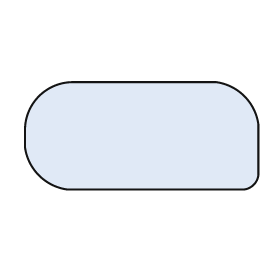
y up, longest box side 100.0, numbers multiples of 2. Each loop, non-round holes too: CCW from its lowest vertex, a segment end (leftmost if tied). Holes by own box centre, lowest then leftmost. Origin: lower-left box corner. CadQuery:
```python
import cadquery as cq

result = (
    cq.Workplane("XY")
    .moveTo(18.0, 0.0)
    .lineTo(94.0, 0.0)
    .threePointArc((98.0, 2.0), (100.0, 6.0))
    .lineTo(100.0, 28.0)
    .threePointArc((94.0, 40.0), (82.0, 46.0))
    .lineTo(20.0, 46.0)
    .threePointArc((6.0, 40.0), (0.0, 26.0))
    .lineTo(0.0, 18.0)
    .threePointArc((6.0, 6.0), (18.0, 0.0))
    .close()
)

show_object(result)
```